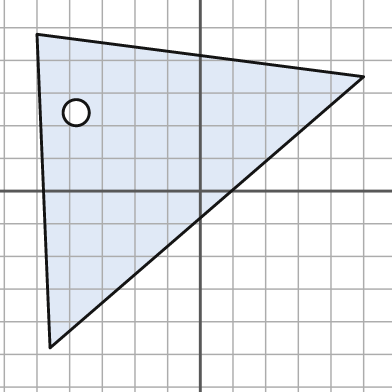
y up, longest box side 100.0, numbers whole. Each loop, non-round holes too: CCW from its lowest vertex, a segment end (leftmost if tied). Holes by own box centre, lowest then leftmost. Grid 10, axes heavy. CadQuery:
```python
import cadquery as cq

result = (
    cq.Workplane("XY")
    .moveTo(-46.0, -48.0)
    .lineTo(50.0, 35.0)
    .lineTo(-50.0, 48.0)
    .close()
    .moveTo(-38.0, 24.0)
    .circle(4.0)
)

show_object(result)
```